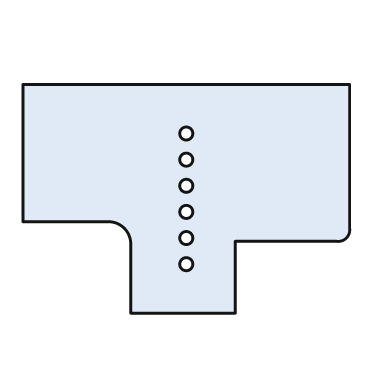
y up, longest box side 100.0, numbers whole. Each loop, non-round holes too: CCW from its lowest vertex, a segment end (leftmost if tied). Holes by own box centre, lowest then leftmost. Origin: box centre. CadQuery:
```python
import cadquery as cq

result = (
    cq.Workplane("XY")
    .moveTo(-17.0, -35.0)
    .lineTo(15.0, -35.0)
    .lineTo(15.0, -13.0)
    .lineTo(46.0, -13.0)
    .threePointArc((49.0, -12.0), (50.0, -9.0))
    .lineTo(50.0, 35.0)
    .lineTo(-50.0, 35.0)
    .lineTo(-50.0, -7.0)
    .lineTo(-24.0, -7.0)
    .threePointArc((-19.0, -9.0), (-17.0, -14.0))
    .close()
    .moveTo(0.0, -20.0)
    .circle(2.0)
    .moveTo(0.0, -12.0)
    .circle(2.0)
    .moveTo(0.0, -4.0)
    .circle(2.0)
    .moveTo(0.0, 4.0)
    .circle(2.0)
    .moveTo(0.0, 12.0)
    .circle(2.0)
    .moveTo(0.0, 20.0)
    .circle(2.0)
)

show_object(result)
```